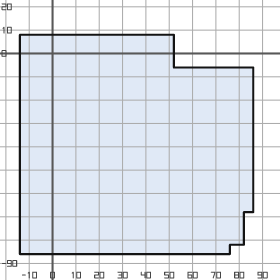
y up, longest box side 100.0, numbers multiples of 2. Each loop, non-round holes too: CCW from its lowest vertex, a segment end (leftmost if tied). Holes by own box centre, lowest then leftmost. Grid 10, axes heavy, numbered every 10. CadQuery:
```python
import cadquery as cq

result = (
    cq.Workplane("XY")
    .moveTo(-14.0, -86.0)
    .lineTo(76.0, -86.0)
    .lineTo(76.0, -82.0)
    .lineTo(82.0, -82.0)
    .lineTo(82.0, -68.0)
    .lineTo(86.0, -68.0)
    .lineTo(86.0, -6.0)
    .lineTo(52.0, -6.0)
    .lineTo(52.0, 8.0)
    .lineTo(-14.0, 8.0)
    .close()
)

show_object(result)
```